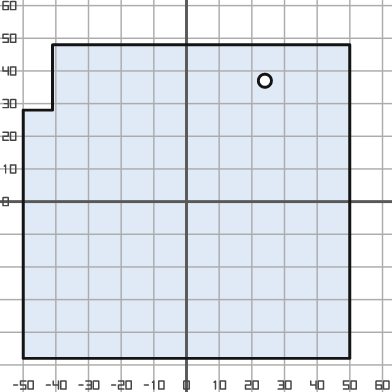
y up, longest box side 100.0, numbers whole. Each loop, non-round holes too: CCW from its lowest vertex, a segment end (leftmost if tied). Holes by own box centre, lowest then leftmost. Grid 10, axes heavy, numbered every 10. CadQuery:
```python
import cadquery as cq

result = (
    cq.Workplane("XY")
    .moveTo(-50.0, -48.0)
    .lineTo(50.0, -48.0)
    .lineTo(50.0, 48.0)
    .lineTo(-41.0, 48.0)
    .lineTo(-41.0, 28.0)
    .lineTo(-50.0, 28.0)
    .close()
    .moveTo(24.0, 37.0)
    .circle(2.0)
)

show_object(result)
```